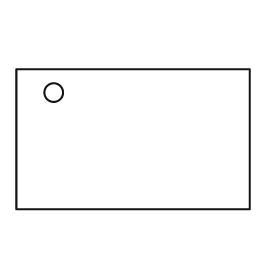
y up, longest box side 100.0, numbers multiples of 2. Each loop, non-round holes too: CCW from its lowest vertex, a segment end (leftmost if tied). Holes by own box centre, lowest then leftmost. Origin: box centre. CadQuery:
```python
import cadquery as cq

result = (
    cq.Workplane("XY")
    .moveTo(-50.0, -30.0)
    .lineTo(50.0, -30.0)
    .lineTo(50.0, 30.0)
    .lineTo(-50.0, 30.0)
    .close()
    .moveTo(-34.0, 20.0)
    .circle(4.0)
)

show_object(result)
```